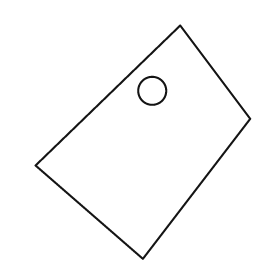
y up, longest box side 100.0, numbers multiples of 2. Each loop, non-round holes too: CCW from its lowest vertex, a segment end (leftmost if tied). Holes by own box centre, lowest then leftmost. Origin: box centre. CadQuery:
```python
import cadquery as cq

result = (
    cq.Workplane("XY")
    .moveTo(0.0, -50.0)
    .lineTo(46.0, 10.0)
    .lineTo(16.0, 50.0)
    .lineTo(-46.0, -10.0)
    .close()
    .moveTo(4.0, 22.0)
    .circle(6.0)
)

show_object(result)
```